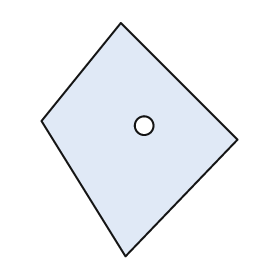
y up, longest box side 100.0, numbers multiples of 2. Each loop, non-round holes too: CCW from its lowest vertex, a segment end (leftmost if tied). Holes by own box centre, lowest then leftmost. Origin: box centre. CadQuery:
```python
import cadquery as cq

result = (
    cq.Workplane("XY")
    .moveTo(-6.0, -50.0)
    .lineTo(42.0, 0.0)
    .lineTo(-8.0, 50.0)
    .lineTo(-42.0, 8.0)
    .close()
    .moveTo(2.0, 6.0)
    .circle(4.0)
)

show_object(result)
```